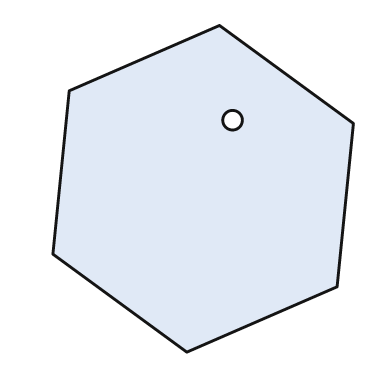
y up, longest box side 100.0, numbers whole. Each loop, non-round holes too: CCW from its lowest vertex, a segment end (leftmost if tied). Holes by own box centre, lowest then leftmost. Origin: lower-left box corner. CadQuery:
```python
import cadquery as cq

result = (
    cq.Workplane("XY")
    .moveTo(41.0, 0.0)
    .lineTo(87.0, 20.0)
    .lineTo(92.0, 70.0)
    .lineTo(51.0, 100.0)
    .lineTo(5.0, 80.0)
    .lineTo(0.0, 30.0)
    .close()
    .moveTo(55.0, 71.0)
    .circle(3.0)
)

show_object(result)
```